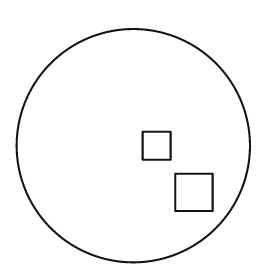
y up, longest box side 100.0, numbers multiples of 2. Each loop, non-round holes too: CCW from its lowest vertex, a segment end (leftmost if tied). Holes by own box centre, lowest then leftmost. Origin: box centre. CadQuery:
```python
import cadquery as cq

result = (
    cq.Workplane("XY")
    .moveTo(0.0, 0.0)
    .circle(50.0)
    .moveTo(18.0, -28.0)
    .lineTo(34.0, -28.0)
    .lineTo(34.0, -12.0)
    .lineTo(18.0, -12.0)
    .close()
    .moveTo(4.0, -6.0)
    .lineTo(16.0, -6.0)
    .lineTo(16.0, 6.0)
    .lineTo(4.0, 6.0)
    .close()
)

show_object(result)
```